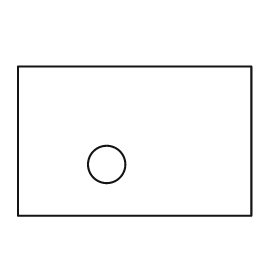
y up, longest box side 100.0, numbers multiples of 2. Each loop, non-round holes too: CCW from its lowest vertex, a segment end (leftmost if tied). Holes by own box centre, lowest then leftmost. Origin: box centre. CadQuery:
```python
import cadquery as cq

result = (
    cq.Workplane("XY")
    .moveTo(-50.0, -32.0)
    .lineTo(50.0, -32.0)
    .lineTo(50.0, 32.0)
    .lineTo(-50.0, 32.0)
    .close()
    .moveTo(-12.0, -10.0)
    .circle(8.0)
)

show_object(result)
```